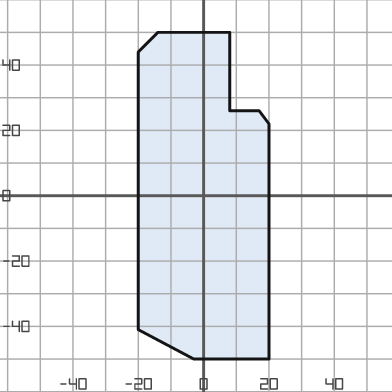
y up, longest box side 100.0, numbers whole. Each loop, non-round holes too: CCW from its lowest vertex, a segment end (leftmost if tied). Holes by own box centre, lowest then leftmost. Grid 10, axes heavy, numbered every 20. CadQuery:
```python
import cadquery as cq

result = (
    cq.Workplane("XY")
    .moveTo(-3.0, -50.0)
    .lineTo(20.0, -50.0)
    .lineTo(20.0, 22.0)
    .lineTo(17.0, 26.0)
    .lineTo(8.0, 26.0)
    .lineTo(8.0, 50.0)
    .lineTo(-14.0, 50.0)
    .lineTo(-20.0, 44.0)
    .lineTo(-20.0, -41.0)
    .close()
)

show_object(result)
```